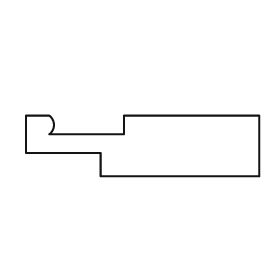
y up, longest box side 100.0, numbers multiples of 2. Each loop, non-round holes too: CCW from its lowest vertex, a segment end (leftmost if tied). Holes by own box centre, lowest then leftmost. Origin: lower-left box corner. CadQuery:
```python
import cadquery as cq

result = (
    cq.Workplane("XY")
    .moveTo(32.0, 0.0)
    .lineTo(100.0, 0.0)
    .lineTo(100.0, 26.0)
    .lineTo(42.0, 26.0)
    .lineTo(42.0, 18.0)
    .lineTo(10.0, 18.0)
    .threePointArc((12.0, 22.0), (10.0, 26.0))
    .lineTo(0.0, 26.0)
    .lineTo(0.0, 10.0)
    .lineTo(32.0, 10.0)
    .close()
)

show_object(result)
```